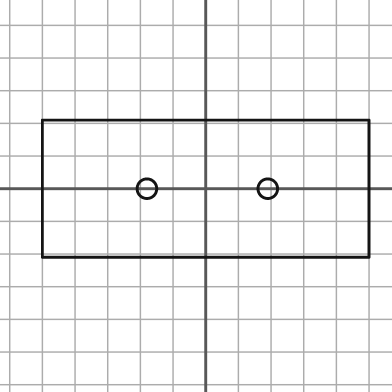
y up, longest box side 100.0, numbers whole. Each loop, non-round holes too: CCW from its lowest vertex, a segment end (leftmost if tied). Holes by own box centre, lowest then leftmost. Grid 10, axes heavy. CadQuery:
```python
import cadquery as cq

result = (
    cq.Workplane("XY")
    .moveTo(-50.0, -21.0)
    .lineTo(50.0, -21.0)
    .lineTo(50.0, 21.0)
    .lineTo(-50.0, 21.0)
    .close()
    .moveTo(-18.0, 0.0)
    .circle(3.0)
    .moveTo(19.0, 0.0)
    .circle(3.0)
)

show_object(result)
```